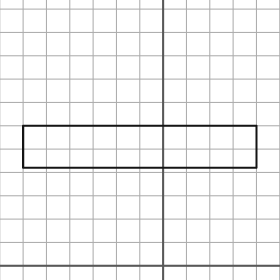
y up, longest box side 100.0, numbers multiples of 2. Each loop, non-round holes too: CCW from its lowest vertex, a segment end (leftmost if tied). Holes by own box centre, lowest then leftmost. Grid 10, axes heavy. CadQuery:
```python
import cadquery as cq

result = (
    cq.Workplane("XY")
    .moveTo(-60.0, 42.0)
    .lineTo(40.0, 42.0)
    .lineTo(40.0, 60.0)
    .lineTo(-60.0, 60.0)
    .close()
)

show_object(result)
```